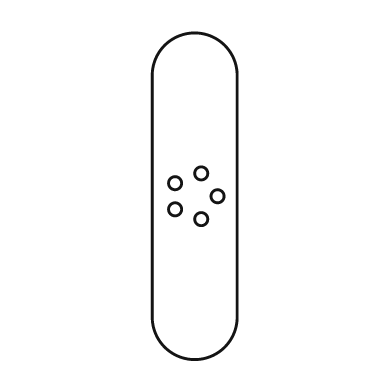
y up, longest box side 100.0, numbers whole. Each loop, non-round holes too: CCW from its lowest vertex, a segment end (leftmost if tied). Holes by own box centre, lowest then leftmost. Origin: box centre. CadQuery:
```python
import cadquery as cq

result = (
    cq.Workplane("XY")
    .moveTo(-13.0, -37.0)
    .threePointArc((0.0, -50.0), (13.0, -37.0))
    .lineTo(13.0, 37.0)
    .threePointArc((0.0, 50.0), (-13.0, 37.0))
    .close()
    .moveTo(2.0, -7.0)
    .circle(2.0)
    .moveTo(-6.0, -4.0)
    .circle(2.0)
    .moveTo(7.0, 0.0)
    .circle(2.0)
    .moveTo(-6.0, 4.0)
    .circle(2.0)
    .moveTo(2.0, 7.0)
    .circle(2.0)
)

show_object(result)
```